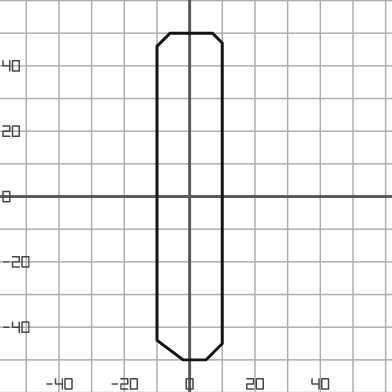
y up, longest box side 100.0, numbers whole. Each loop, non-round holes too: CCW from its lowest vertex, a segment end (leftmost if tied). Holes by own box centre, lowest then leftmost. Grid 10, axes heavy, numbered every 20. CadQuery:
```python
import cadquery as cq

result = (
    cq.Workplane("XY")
    .moveTo(-2.0, -50.0)
    .lineTo(5.0, -50.0)
    .lineTo(10.0, -45.0)
    .lineTo(10.0, 47.0)
    .lineTo(7.0, 50.0)
    .lineTo(-6.0, 50.0)
    .lineTo(-10.0, 46.0)
    .lineTo(-10.0, -44.0)
    .close()
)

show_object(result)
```